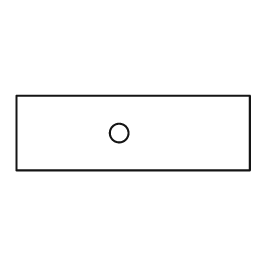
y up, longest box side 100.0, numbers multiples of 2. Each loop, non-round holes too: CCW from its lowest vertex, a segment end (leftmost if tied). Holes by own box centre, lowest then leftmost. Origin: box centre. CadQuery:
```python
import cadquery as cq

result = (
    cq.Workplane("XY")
    .moveTo(-50.0, -16.0)
    .lineTo(50.0, -16.0)
    .lineTo(50.0, 16.0)
    .lineTo(-50.0, 16.0)
    .close()
    .moveTo(-6.0, 0.0)
    .circle(4.0)
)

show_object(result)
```